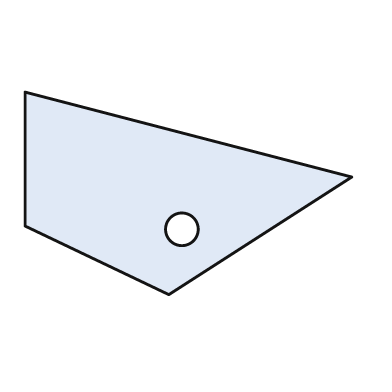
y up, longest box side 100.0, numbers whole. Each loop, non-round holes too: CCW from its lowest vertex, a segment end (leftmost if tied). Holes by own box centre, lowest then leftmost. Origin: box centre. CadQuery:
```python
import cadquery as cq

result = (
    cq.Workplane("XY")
    .moveTo(-6.0, -31.0)
    .lineTo(50.0, 5.0)
    .lineTo(-50.0, 31.0)
    .lineTo(-50.0, -10.0)
    .close()
    .moveTo(-2.0, -11.0)
    .circle(5.0)
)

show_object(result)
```